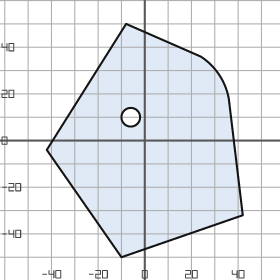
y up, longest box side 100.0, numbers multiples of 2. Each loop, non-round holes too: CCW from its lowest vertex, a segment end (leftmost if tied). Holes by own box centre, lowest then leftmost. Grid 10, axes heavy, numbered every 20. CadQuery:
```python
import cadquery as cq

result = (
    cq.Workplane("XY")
    .moveTo(-10.0, -50.0)
    .lineTo(42.0, -32.0)
    .lineTo(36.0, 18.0)
    .threePointArc((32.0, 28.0), (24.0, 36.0))
    .lineTo(-8.0, 50.0)
    .lineTo(-42.0, -4.0)
    .close()
    .moveTo(-6.0, 10.0)
    .circle(4.0)
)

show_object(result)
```